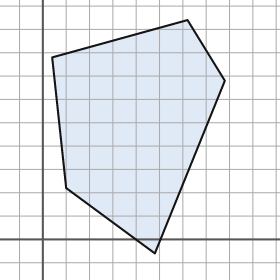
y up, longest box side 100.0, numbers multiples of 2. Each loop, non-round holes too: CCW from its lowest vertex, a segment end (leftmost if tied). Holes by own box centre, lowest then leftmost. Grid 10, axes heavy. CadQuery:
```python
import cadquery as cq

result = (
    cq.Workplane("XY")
    .moveTo(48.0, -6.0)
    .lineTo(78.0, 68.0)
    .lineTo(62.0, 94.0)
    .lineTo(4.0, 78.0)
    .lineTo(10.0, 22.0)
    .close()
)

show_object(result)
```